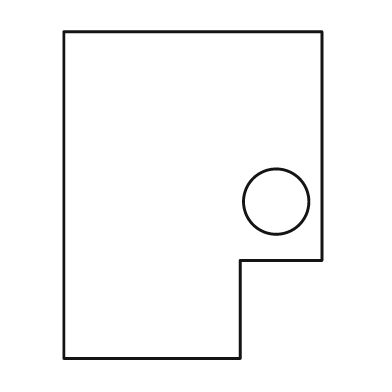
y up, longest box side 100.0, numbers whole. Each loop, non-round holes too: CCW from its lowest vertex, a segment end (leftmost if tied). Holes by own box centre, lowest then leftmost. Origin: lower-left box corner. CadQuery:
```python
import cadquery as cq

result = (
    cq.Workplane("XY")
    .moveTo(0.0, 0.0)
    .lineTo(54.0, 0.0)
    .lineTo(54.0, 30.0)
    .lineTo(79.0, 30.0)
    .lineTo(79.0, 100.0)
    .lineTo(0.0, 100.0)
    .close()
    .moveTo(65.0, 48.0)
    .circle(10.0)
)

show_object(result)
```